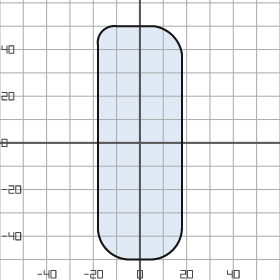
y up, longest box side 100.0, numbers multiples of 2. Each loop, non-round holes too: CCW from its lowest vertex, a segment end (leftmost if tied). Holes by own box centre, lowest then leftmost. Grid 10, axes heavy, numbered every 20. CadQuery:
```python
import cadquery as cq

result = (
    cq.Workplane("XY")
    .moveTo(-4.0, -50.0)
    .lineTo(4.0, -50.0)
    .threePointArc((14.0, -46.0), (18.0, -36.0))
    .lineTo(18.0, 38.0)
    .threePointArc((14.0, 46.0), (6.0, 50.0))
    .lineTo(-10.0, 50.0)
    .threePointArc((-16.0, 48.0), (-18.0, 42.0))
    .lineTo(-18.0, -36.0)
    .threePointArc((-14.0, -46.0), (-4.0, -50.0))
    .close()
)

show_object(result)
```